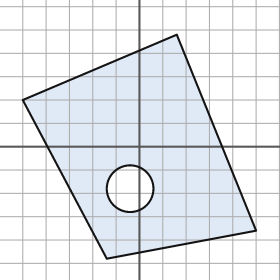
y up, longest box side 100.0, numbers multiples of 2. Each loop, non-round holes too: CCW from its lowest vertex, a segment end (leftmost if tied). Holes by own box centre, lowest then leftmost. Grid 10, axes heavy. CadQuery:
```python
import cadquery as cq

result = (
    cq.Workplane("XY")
    .moveTo(-14.0, -48.0)
    .lineTo(50.0, -36.0)
    .lineTo(16.0, 48.0)
    .lineTo(-50.0, 20.0)
    .close()
    .moveTo(-4.0, -18.0)
    .circle(10.0)
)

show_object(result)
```